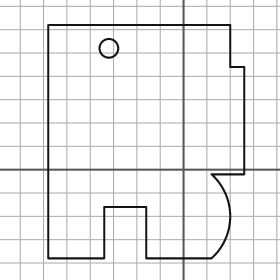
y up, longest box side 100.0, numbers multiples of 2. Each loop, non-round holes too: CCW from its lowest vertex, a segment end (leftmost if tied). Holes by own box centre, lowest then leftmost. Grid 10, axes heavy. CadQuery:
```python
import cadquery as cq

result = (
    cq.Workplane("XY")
    .moveTo(-58.0, -38.0)
    .lineTo(-34.0, -38.0)
    .lineTo(-34.0, -16.0)
    .lineTo(-16.0, -16.0)
    .lineTo(-16.0, -38.0)
    .lineTo(12.0, -38.0)
    .threePointArc((20.0, -20.0), (12.0, -2.0))
    .lineTo(26.0, -2.0)
    .lineTo(26.0, 44.0)
    .lineTo(20.0, 44.0)
    .lineTo(20.0, 62.0)
    .lineTo(-58.0, 62.0)
    .close()
    .moveTo(-32.0, 52.0)
    .circle(4.0)
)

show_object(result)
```